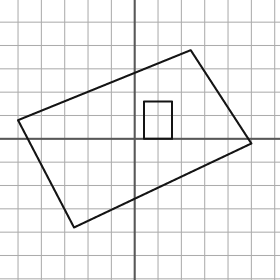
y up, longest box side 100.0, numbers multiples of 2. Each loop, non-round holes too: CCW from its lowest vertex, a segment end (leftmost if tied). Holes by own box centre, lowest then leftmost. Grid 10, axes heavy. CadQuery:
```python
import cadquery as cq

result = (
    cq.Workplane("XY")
    .moveTo(-26.0, -38.0)
    .lineTo(50.0, -2.0)
    .lineTo(24.0, 38.0)
    .lineTo(-50.0, 8.0)
    .close()
    .moveTo(4.0, 0.0)
    .lineTo(16.0, 0.0)
    .lineTo(16.0, 16.0)
    .lineTo(4.0, 16.0)
    .close()
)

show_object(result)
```